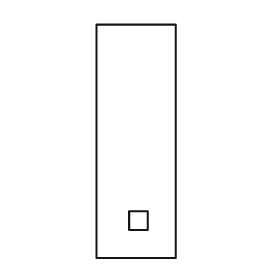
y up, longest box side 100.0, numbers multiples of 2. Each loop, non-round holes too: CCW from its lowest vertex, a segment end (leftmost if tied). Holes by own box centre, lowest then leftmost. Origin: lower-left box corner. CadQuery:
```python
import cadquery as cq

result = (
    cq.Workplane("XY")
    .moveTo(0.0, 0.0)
    .lineTo(34.0, 0.0)
    .lineTo(34.0, 100.0)
    .lineTo(0.0, 100.0)
    .close()
    .moveTo(14.0, 12.0)
    .lineTo(22.0, 12.0)
    .lineTo(22.0, 20.0)
    .lineTo(14.0, 20.0)
    .close()
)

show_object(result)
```